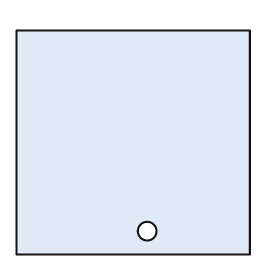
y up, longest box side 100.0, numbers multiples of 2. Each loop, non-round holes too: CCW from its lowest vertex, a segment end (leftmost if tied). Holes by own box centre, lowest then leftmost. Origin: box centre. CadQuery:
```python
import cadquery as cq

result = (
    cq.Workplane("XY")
    .moveTo(-50.0, -48.0)
    .lineTo(50.0, -48.0)
    .lineTo(50.0, 48.0)
    .lineTo(-50.0, 48.0)
    .close()
    .moveTo(6.0, -38.0)
    .circle(4.0)
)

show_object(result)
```